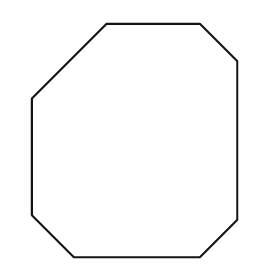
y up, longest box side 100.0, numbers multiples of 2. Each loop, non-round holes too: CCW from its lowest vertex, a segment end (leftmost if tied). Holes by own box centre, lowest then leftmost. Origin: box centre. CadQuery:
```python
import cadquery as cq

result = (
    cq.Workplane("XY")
    .moveTo(-26.0, -50.0)
    .lineTo(28.0, -50.0)
    .lineTo(44.0, -34.0)
    .lineTo(44.0, 34.0)
    .lineTo(28.0, 50.0)
    .lineTo(-12.0, 50.0)
    .lineTo(-44.0, 18.0)
    .lineTo(-44.0, -32.0)
    .close()
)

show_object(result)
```